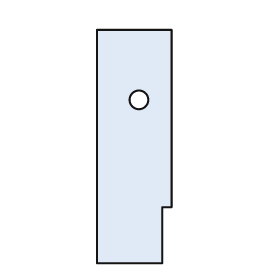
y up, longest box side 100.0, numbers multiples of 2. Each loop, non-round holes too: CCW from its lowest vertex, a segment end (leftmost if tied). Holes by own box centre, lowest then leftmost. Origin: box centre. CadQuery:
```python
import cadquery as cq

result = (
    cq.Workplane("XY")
    .moveTo(-16.0, -50.0)
    .lineTo(12.0, -50.0)
    .lineTo(12.0, -26.0)
    .lineTo(16.0, -26.0)
    .lineTo(16.0, 50.0)
    .lineTo(-16.0, 50.0)
    .close()
    .moveTo(2.0, 20.0)
    .circle(4.0)
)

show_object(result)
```